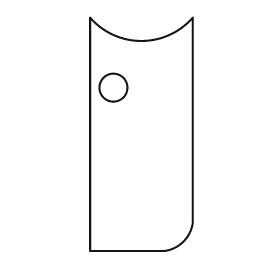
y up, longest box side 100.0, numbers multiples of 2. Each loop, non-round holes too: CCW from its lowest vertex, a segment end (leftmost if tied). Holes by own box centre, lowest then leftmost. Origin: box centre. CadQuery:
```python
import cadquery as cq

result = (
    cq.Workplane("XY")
    .moveTo(-22.0, -50.0)
    .lineTo(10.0, -50.0)
    .threePointArc((18.0, -46.0), (22.0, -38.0))
    .lineTo(22.0, 50.0)
    .threePointArc((0.0, 40.0), (-22.0, 50.0))
    .close()
    .moveTo(-12.0, 20.0)
    .circle(6.0)
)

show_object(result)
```